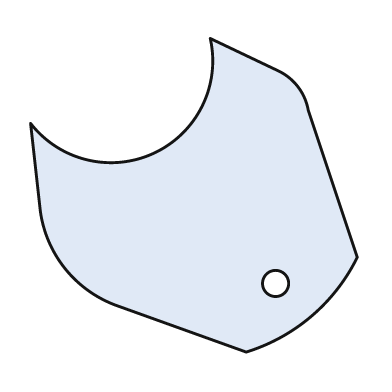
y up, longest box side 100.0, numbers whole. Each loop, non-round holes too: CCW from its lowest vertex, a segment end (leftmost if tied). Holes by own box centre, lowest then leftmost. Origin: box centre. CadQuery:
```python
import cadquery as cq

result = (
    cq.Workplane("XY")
    .moveTo(16.0, -48.0)
    .threePointArc((36.0, -37.0), (50.0, -19.0))
    .lineTo(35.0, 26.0)
    .threePointArc((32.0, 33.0), (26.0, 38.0))
    .lineTo(5.0, 48.0)
    .threePointArc((-12.0, 13.0), (-50.0, 22.0))
    .lineTo(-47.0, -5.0)
    .threePointArc((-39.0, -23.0), (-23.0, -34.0))
    .close()
    .moveTo(25.0, -27.0)
    .circle(4.0)
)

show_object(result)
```